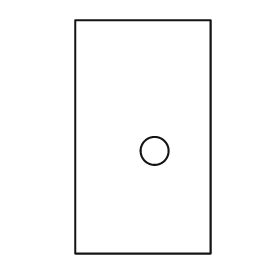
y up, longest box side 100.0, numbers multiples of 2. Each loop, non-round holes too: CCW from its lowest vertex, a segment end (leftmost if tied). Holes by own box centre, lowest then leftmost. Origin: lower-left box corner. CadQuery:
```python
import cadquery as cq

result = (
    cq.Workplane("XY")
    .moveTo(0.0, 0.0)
    .lineTo(58.0, 0.0)
    .lineTo(58.0, 100.0)
    .lineTo(0.0, 100.0)
    .close()
    .moveTo(34.0, 44.0)
    .circle(6.0)
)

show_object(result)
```